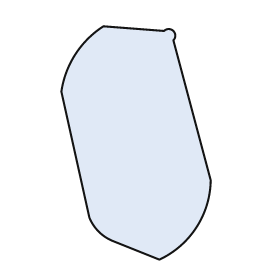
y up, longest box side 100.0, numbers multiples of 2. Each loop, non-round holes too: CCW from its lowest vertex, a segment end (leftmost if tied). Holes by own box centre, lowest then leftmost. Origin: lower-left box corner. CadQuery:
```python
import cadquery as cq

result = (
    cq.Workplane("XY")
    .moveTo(42.0, 0.0)
    .threePointArc((58.0, 14.0), (64.0, 34.0))
    .lineTo(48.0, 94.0)
    .threePointArc((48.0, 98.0), (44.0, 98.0))
    .lineTo(18.0, 100.0)
    .threePointArc((6.0, 88.0), (0.0, 72.0))
    .lineTo(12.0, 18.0)
    .threePointArc((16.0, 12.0), (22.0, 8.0))
    .close()
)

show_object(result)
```